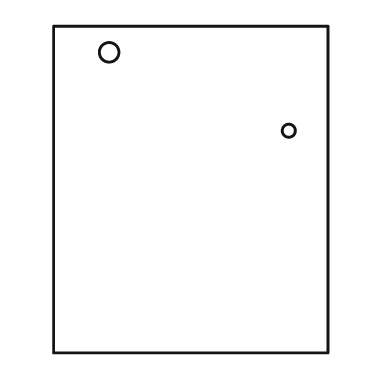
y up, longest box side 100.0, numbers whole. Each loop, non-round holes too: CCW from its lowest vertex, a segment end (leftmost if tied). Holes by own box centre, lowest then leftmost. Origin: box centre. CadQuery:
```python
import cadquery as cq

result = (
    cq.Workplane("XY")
    .moveTo(-42.0, -50.0)
    .lineTo(42.0, -50.0)
    .lineTo(42.0, 50.0)
    .lineTo(-42.0, 50.0)
    .close()
    .moveTo(30.0, 18.0)
    .circle(2.0)
    .moveTo(-25.0, 42.0)
    .circle(3.0)
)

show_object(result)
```